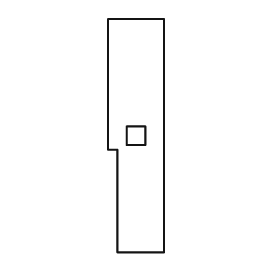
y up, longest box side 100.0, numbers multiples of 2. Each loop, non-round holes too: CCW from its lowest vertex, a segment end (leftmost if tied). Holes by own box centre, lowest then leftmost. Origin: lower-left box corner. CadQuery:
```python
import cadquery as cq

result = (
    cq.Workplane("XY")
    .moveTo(4.0, 0.0)
    .lineTo(24.0, 0.0)
    .lineTo(24.0, 100.0)
    .lineTo(0.0, 100.0)
    .lineTo(0.0, 44.0)
    .lineTo(4.0, 44.0)
    .close()
    .moveTo(8.0, 46.0)
    .lineTo(16.0, 46.0)
    .lineTo(16.0, 54.0)
    .lineTo(8.0, 54.0)
    .close()
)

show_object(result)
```